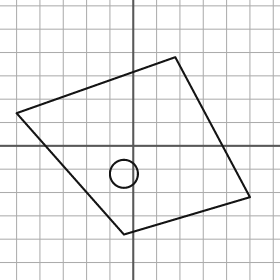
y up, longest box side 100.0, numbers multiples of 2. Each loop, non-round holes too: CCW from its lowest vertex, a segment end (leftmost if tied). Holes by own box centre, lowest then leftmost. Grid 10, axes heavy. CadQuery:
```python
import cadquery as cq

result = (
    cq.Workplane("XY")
    .moveTo(-4.0, -38.0)
    .lineTo(50.0, -22.0)
    .lineTo(18.0, 38.0)
    .lineTo(-50.0, 14.0)
    .close()
    .moveTo(-4.0, -12.0)
    .circle(6.0)
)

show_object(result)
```